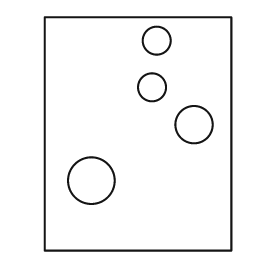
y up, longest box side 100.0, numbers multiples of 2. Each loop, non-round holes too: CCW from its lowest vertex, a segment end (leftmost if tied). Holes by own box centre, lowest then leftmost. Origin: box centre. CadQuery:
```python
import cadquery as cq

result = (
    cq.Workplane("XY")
    .moveTo(-40.0, -50.0)
    .lineTo(40.0, -50.0)
    .lineTo(40.0, 50.0)
    .lineTo(-40.0, 50.0)
    .close()
    .moveTo(-20.0, -20.0)
    .circle(10.0)
    .moveTo(24.0, 4.0)
    .circle(8.0)
    .moveTo(6.0, 20.0)
    .circle(6.0)
    .moveTo(8.0, 40.0)
    .circle(6.0)
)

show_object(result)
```